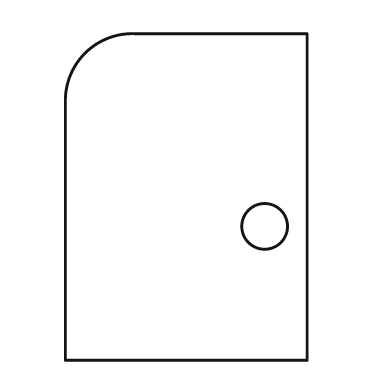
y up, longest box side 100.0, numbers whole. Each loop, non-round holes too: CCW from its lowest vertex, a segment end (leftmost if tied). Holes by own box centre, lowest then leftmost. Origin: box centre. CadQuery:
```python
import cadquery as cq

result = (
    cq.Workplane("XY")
    .moveTo(-37.0, -50.0)
    .lineTo(37.0, -50.0)
    .lineTo(37.0, 50.0)
    .lineTo(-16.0, 50.0)
    .threePointArc((-31.0, 44.0), (-37.0, 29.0))
    .close()
    .moveTo(24.0, -9.0)
    .circle(7.0)
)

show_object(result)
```